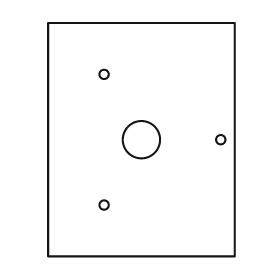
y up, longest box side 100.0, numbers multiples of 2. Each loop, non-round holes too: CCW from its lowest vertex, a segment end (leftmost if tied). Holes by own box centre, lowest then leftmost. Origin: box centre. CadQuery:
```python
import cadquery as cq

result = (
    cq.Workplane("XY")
    .moveTo(-40.0, -50.0)
    .lineTo(40.0, -50.0)
    .lineTo(40.0, 50.0)
    .lineTo(-40.0, 50.0)
    .close()
    .moveTo(-16.0, -28.0)
    .circle(2.0)
    .moveTo(0.0, 0.0)
    .circle(8.0)
    .moveTo(34.0, 0.0)
    .circle(2.0)
    .moveTo(-16.0, 28.0)
    .circle(2.0)
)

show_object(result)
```